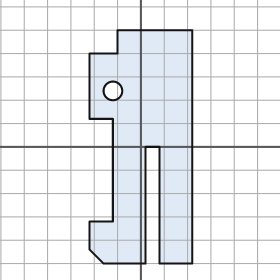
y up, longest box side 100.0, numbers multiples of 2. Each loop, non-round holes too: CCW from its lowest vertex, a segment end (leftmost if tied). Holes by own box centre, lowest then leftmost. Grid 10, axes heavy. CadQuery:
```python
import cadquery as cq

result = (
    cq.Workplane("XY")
    .moveTo(-16.0, -50.0)
    .lineTo(2.0, -50.0)
    .lineTo(2.0, 0.0)
    .lineTo(8.0, 0.0)
    .lineTo(8.0, -50.0)
    .lineTo(22.0, -50.0)
    .lineTo(22.0, 50.0)
    .lineTo(-10.0, 50.0)
    .lineTo(-10.0, 40.0)
    .lineTo(-22.0, 40.0)
    .lineTo(-22.0, 12.0)
    .lineTo(-12.0, 12.0)
    .lineTo(-12.0, -32.0)
    .lineTo(-22.0, -32.0)
    .lineTo(-22.0, -44.0)
    .close()
    .moveTo(-12.0, 24.0)
    .circle(4.0)
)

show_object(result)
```